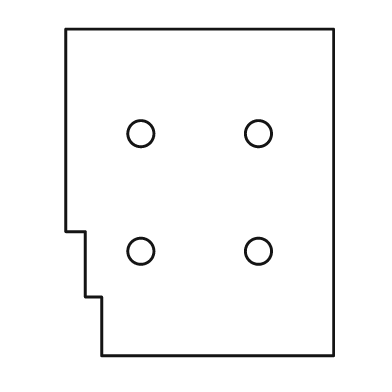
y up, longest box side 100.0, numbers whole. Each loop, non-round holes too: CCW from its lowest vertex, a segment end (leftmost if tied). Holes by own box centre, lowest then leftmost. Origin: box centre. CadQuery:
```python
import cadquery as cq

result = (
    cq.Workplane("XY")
    .moveTo(-30.0, -50.0)
    .lineTo(41.0, -50.0)
    .lineTo(41.0, 50.0)
    .lineTo(-41.0, 50.0)
    .lineTo(-41.0, -12.0)
    .lineTo(-35.0, -12.0)
    .lineTo(-35.0, -32.0)
    .lineTo(-30.0, -32.0)
    .close()
    .moveTo(-18.0, -18.0)
    .circle(4.0)
    .moveTo(18.0, -18.0)
    .circle(4.0)
    .moveTo(-18.0, 18.0)
    .circle(4.0)
    .moveTo(18.0, 18.0)
    .circle(4.0)
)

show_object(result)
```